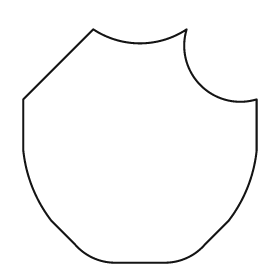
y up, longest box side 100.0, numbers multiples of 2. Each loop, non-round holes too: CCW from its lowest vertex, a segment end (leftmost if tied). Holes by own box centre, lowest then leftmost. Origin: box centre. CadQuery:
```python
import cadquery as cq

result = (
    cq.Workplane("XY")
    .moveTo(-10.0, -50.0)
    .lineTo(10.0, -50.0)
    .threePointArc((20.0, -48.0), (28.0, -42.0))
    .lineTo(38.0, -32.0)
    .threePointArc((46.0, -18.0), (50.0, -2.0))
    .lineTo(50.0, 20.0)
    .threePointArc((26.0, 26.0), (20.0, 50.0))
    .threePointArc((0.0, 44.0), (-20.0, 50.0))
    .lineTo(-50.0, 20.0)
    .lineTo(-50.0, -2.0)
    .threePointArc((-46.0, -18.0), (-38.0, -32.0))
    .lineTo(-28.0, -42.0)
    .threePointArc((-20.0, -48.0), (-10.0, -50.0))
    .close()
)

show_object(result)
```